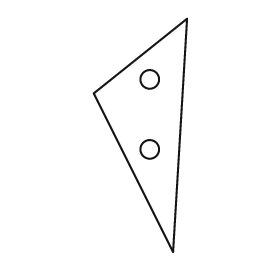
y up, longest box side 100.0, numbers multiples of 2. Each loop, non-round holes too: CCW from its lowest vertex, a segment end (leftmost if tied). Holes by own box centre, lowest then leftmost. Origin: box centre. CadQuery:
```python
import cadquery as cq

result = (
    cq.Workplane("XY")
    .moveTo(14.0, -50.0)
    .lineTo(20.0, 50.0)
    .lineTo(-20.0, 18.0)
    .close()
    .moveTo(4.0, -6.0)
    .circle(4.0)
    .moveTo(4.0, 24.0)
    .circle(4.0)
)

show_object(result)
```